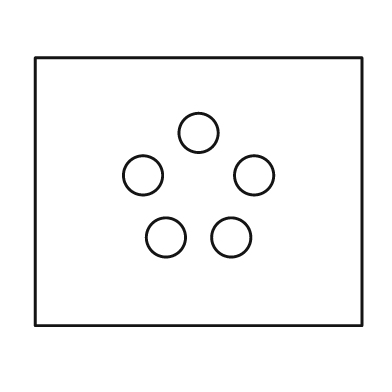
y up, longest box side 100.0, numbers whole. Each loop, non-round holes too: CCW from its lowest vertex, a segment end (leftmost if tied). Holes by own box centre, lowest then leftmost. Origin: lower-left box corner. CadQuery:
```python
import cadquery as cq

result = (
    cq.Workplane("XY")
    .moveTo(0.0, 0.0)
    .lineTo(100.0, 0.0)
    .lineTo(100.0, 82.0)
    .lineTo(0.0, 82.0)
    .close()
    .moveTo(40.0, 27.0)
    .circle(6.0)
    .moveTo(60.0, 27.0)
    .circle(6.0)
    .moveTo(33.0, 46.0)
    .circle(6.0)
    .moveTo(67.0, 46.0)
    .circle(6.0)
    .moveTo(50.0, 59.0)
    .circle(6.0)
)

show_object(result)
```